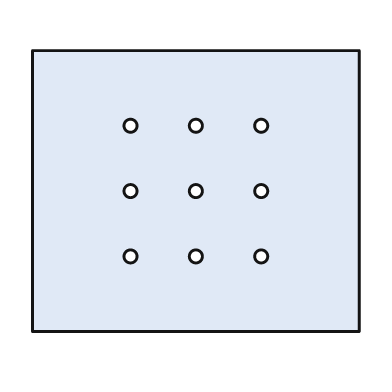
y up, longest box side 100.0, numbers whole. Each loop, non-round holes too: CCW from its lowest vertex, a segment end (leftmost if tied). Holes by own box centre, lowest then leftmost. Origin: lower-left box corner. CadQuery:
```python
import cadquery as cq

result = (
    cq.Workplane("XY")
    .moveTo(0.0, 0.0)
    .lineTo(100.0, 0.0)
    .lineTo(100.0, 86.0)
    .lineTo(0.0, 86.0)
    .close()
    .moveTo(30.0, 23.0)
    .circle(2.0)
    .moveTo(50.0, 23.0)
    .circle(2.0)
    .moveTo(70.0, 23.0)
    .circle(2.0)
    .moveTo(30.0, 43.0)
    .circle(2.0)
    .moveTo(50.0, 43.0)
    .circle(2.0)
    .moveTo(70.0, 43.0)
    .circle(2.0)
    .moveTo(30.0, 63.0)
    .circle(2.0)
    .moveTo(50.0, 63.0)
    .circle(2.0)
    .moveTo(70.0, 63.0)
    .circle(2.0)
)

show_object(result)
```